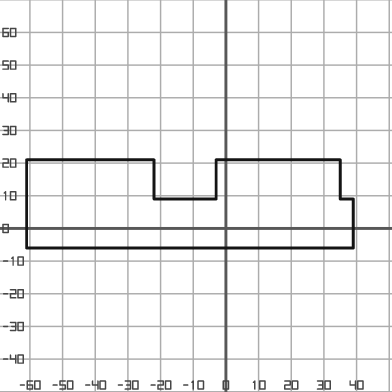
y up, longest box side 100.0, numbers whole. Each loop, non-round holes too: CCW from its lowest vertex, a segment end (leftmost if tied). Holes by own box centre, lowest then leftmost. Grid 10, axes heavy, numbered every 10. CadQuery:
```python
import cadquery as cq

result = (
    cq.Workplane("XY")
    .moveTo(-61.0, -6.0)
    .lineTo(39.0, -6.0)
    .lineTo(39.0, 9.0)
    .lineTo(35.0, 9.0)
    .lineTo(35.0, 21.0)
    .lineTo(-3.0, 21.0)
    .lineTo(-3.0, 9.0)
    .lineTo(-22.0, 9.0)
    .lineTo(-22.0, 21.0)
    .lineTo(-61.0, 21.0)
    .close()
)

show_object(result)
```